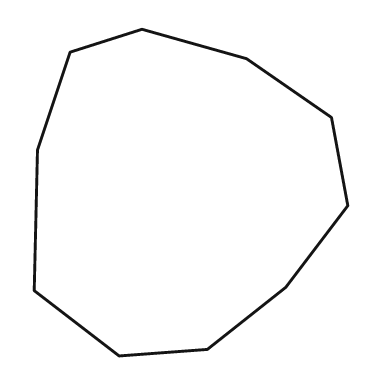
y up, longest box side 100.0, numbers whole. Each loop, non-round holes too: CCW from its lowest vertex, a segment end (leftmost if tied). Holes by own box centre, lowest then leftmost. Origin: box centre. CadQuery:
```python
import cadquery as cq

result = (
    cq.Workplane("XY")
    .moveTo(-22.0, -50.0)
    .lineTo(5.0, -48.0)
    .lineTo(29.0, -29.0)
    .lineTo(48.0, -4.0)
    .lineTo(43.0, 23.0)
    .lineTo(17.0, 41.0)
    .lineTo(-15.0, 50.0)
    .lineTo(-37.0, 43.0)
    .lineTo(-47.0, 13.0)
    .lineTo(-48.0, -30.0)
    .close()
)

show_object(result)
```